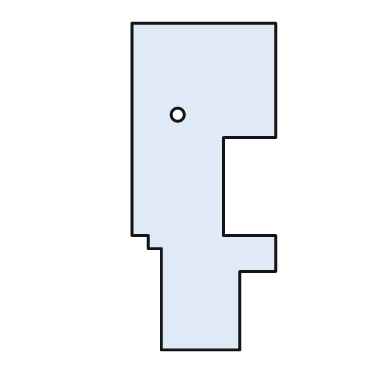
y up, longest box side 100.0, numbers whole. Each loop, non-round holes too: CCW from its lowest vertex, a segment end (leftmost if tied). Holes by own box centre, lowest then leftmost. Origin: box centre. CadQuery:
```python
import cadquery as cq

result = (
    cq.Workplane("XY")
    .moveTo(-13.0, -50.0)
    .lineTo(11.0, -50.0)
    .lineTo(11.0, -26.0)
    .lineTo(22.0, -26.0)
    .lineTo(22.0, -15.0)
    .lineTo(6.0, -15.0)
    .lineTo(6.0, 15.0)
    .lineTo(22.0, 15.0)
    .lineTo(22.0, 50.0)
    .lineTo(-22.0, 50.0)
    .lineTo(-22.0, -15.0)
    .lineTo(-17.0, -15.0)
    .lineTo(-17.0, -19.0)
    .lineTo(-13.0, -19.0)
    .close()
    .moveTo(-8.0, 22.0)
    .circle(2.0)
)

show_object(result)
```